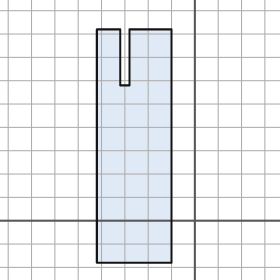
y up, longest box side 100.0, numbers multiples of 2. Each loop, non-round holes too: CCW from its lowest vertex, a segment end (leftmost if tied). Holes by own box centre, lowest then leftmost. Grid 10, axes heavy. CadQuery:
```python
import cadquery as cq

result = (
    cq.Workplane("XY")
    .moveTo(-42.0, -18.0)
    .lineTo(-10.0, -18.0)
    .lineTo(-10.0, 82.0)
    .lineTo(-28.0, 82.0)
    .lineTo(-28.0, 58.0)
    .lineTo(-32.0, 58.0)
    .lineTo(-32.0, 82.0)
    .lineTo(-42.0, 82.0)
    .close()
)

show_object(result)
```